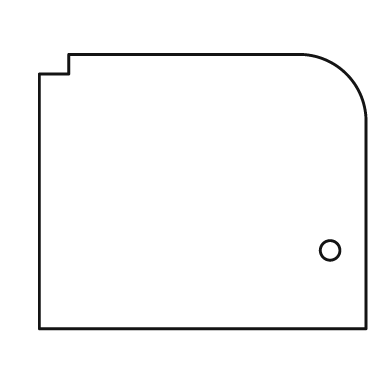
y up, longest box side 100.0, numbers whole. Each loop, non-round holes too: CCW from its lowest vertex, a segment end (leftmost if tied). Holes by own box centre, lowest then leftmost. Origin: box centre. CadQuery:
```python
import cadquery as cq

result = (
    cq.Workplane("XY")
    .moveTo(-50.0, -42.0)
    .lineTo(50.0, -42.0)
    .lineTo(50.0, 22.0)
    .threePointArc((44.0, 36.0), (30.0, 42.0))
    .lineTo(-41.0, 42.0)
    .lineTo(-41.0, 36.0)
    .lineTo(-50.0, 36.0)
    .close()
    .moveTo(39.0, -18.0)
    .circle(3.0)
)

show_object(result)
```